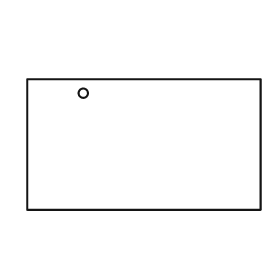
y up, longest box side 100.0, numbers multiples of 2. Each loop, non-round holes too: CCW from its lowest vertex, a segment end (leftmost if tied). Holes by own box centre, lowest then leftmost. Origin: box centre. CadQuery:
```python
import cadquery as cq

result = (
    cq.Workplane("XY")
    .moveTo(-50.0, -28.0)
    .lineTo(50.0, -28.0)
    .lineTo(50.0, 28.0)
    .lineTo(-50.0, 28.0)
    .close()
    .moveTo(-26.0, 22.0)
    .circle(2.0)
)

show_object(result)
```